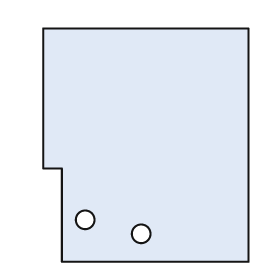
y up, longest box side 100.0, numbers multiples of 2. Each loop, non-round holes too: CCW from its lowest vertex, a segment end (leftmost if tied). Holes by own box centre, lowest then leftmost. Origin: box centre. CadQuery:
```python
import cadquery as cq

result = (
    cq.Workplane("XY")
    .moveTo(-36.0, -50.0)
    .lineTo(44.0, -50.0)
    .lineTo(44.0, 50.0)
    .lineTo(-44.0, 50.0)
    .lineTo(-44.0, -10.0)
    .lineTo(-36.0, -10.0)
    .close()
    .moveTo(-2.0, -38.0)
    .circle(4.0)
    .moveTo(-26.0, -32.0)
    .circle(4.0)
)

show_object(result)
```